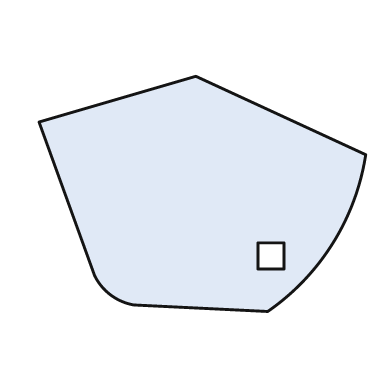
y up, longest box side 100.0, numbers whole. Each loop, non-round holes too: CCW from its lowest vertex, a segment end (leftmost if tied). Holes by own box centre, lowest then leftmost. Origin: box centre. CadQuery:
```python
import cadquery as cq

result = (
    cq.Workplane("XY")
    .moveTo(20.0, -36.0)
    .threePointArc((40.0, -15.0), (50.0, 12.0))
    .lineTo(-2.0, 36.0)
    .lineTo(-50.0, 22.0)
    .lineTo(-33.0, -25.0)
    .threePointArc((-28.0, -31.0), (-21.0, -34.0))
    .close()
    .moveTo(17.0, -23.0)
    .lineTo(25.0, -23.0)
    .lineTo(25.0, -15.0)
    .lineTo(17.0, -15.0)
    .close()
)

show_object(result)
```